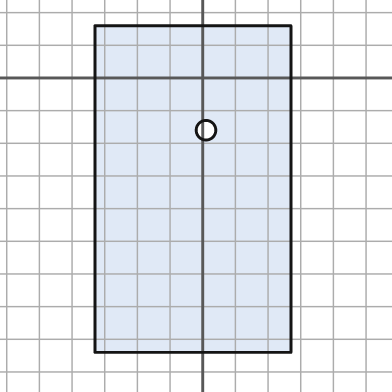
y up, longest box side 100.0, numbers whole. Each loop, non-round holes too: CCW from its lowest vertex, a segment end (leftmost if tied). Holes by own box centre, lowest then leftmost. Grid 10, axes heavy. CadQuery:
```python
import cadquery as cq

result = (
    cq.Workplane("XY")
    .moveTo(-33.0, -84.0)
    .lineTo(27.0, -84.0)
    .lineTo(27.0, 16.0)
    .lineTo(-33.0, 16.0)
    .close()
    .moveTo(1.0, -16.0)
    .circle(3.0)
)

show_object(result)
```